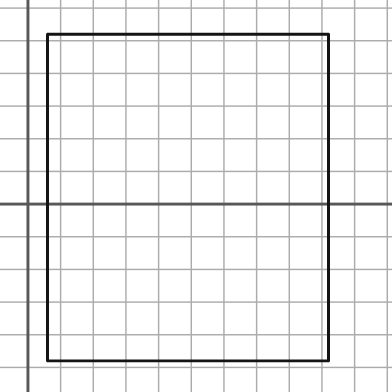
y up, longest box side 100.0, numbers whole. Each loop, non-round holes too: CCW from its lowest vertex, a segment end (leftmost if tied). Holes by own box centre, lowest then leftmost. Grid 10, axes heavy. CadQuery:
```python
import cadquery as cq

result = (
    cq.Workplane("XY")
    .moveTo(6.0, -48.0)
    .lineTo(92.0, -48.0)
    .lineTo(92.0, 52.0)
    .lineTo(6.0, 52.0)
    .close()
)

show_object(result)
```